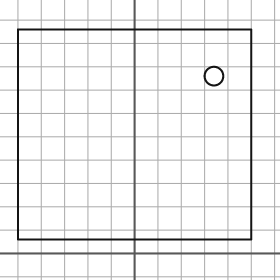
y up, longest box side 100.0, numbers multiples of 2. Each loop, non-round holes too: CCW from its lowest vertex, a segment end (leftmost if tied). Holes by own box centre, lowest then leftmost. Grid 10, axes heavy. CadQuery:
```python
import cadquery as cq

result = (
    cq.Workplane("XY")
    .moveTo(-50.0, 6.0)
    .lineTo(50.0, 6.0)
    .lineTo(50.0, 96.0)
    .lineTo(-50.0, 96.0)
    .close()
    .moveTo(34.0, 76.0)
    .circle(4.0)
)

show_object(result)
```